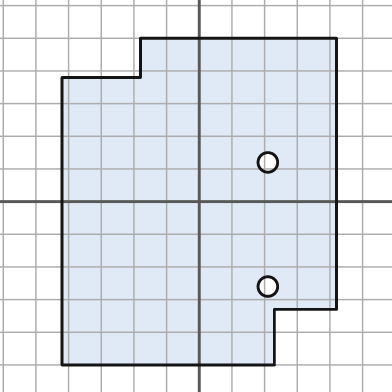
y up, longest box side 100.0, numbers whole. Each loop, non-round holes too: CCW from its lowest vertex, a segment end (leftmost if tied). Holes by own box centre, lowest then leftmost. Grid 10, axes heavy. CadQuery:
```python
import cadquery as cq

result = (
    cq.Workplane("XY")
    .moveTo(-42.0, -50.0)
    .lineTo(23.0, -50.0)
    .lineTo(23.0, -33.0)
    .lineTo(42.0, -33.0)
    .lineTo(42.0, 50.0)
    .lineTo(-18.0, 50.0)
    .lineTo(-18.0, 38.0)
    .lineTo(-42.0, 38.0)
    .close()
    .moveTo(21.0, -26.0)
    .circle(3.0)
    .moveTo(21.0, 12.0)
    .circle(3.0)
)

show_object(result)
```